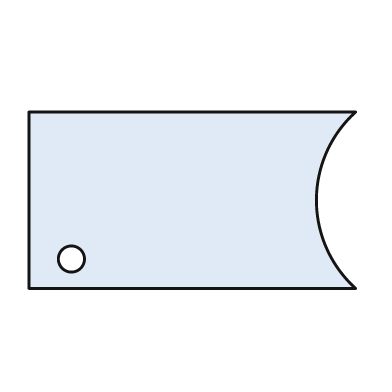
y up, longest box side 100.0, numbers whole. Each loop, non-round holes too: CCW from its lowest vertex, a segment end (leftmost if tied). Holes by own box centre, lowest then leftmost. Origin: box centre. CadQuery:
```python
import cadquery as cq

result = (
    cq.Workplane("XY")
    .moveTo(-50.0, -27.0)
    .lineTo(50.0, -27.0)
    .threePointArc((38.0, 0.0), (50.0, 27.0))
    .lineTo(-50.0, 27.0)
    .close()
    .moveTo(-37.0, -18.0)
    .circle(4.0)
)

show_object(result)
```